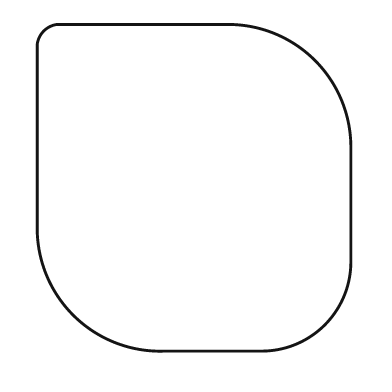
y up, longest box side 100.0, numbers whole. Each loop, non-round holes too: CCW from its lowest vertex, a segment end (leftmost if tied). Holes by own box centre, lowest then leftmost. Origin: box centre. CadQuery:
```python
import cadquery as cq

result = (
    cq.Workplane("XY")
    .moveTo(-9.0, -50.0)
    .lineTo(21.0, -50.0)
    .threePointArc((40.0, -42.0), (48.0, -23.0))
    .lineTo(48.0, 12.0)
    .threePointArc((37.0, 39.0), (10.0, 50.0))
    .lineTo(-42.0, 50.0)
    .threePointArc((-46.0, 48.0), (-48.0, 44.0))
    .lineTo(-48.0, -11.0)
    .threePointArc((-37.0, -39.0), (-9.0, -50.0))
    .close()
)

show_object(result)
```